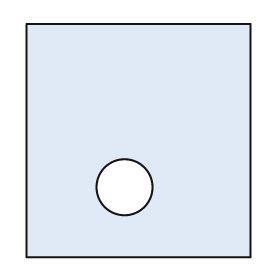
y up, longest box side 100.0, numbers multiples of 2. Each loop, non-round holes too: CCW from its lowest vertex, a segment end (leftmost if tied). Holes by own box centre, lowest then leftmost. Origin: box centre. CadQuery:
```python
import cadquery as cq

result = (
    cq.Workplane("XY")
    .moveTo(-48.0, -50.0)
    .lineTo(48.0, -50.0)
    .lineTo(48.0, 50.0)
    .lineTo(-48.0, 50.0)
    .close()
    .moveTo(-6.0, -20.0)
    .circle(12.0)
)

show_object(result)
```